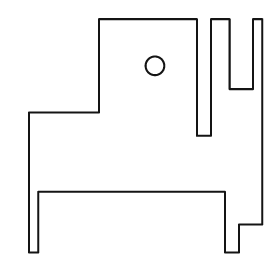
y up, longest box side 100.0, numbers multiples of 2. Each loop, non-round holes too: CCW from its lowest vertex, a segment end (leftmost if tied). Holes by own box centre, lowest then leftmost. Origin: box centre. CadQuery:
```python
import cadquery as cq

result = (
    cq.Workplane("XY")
    .moveTo(-50.0, -50.0)
    .lineTo(-46.0, -50.0)
    .lineTo(-46.0, -24.0)
    .lineTo(34.0, -24.0)
    .lineTo(34.0, -50.0)
    .lineTo(40.0, -50.0)
    .lineTo(40.0, -38.0)
    .lineTo(50.0, -38.0)
    .lineTo(50.0, 50.0)
    .lineTo(46.0, 50.0)
    .lineTo(46.0, 20.0)
    .lineTo(36.0, 20.0)
    .lineTo(36.0, 50.0)
    .lineTo(28.0, 50.0)
    .lineTo(28.0, 0.0)
    .lineTo(22.0, 0.0)
    .lineTo(22.0, 50.0)
    .lineTo(-20.0, 50.0)
    .lineTo(-20.0, 10.0)
    .lineTo(-50.0, 10.0)
    .close()
    .moveTo(4.0, 30.0)
    .circle(4.0)
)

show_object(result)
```